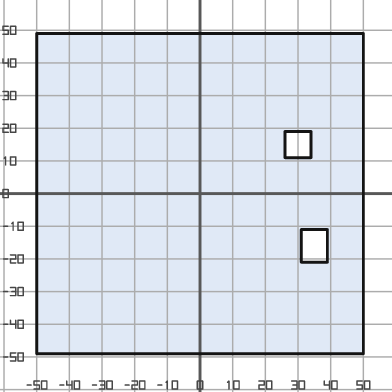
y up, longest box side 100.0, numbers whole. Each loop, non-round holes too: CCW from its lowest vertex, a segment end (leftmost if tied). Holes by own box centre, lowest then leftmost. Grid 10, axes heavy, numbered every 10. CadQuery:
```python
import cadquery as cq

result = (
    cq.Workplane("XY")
    .moveTo(-50.0, -49.0)
    .lineTo(50.0, -49.0)
    .lineTo(50.0, 49.0)
    .lineTo(-50.0, 49.0)
    .close()
    .moveTo(31.0, -21.0)
    .lineTo(39.0, -21.0)
    .lineTo(39.0, -11.0)
    .lineTo(31.0, -11.0)
    .close()
    .moveTo(26.0, 11.0)
    .lineTo(34.0, 11.0)
    .lineTo(34.0, 19.0)
    .lineTo(26.0, 19.0)
    .close()
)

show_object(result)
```